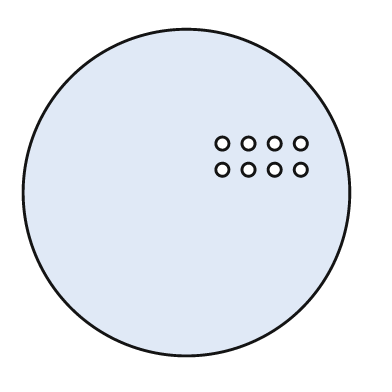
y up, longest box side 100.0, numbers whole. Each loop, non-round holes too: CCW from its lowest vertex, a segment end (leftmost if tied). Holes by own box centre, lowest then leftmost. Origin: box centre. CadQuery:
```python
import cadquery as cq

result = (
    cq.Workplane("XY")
    .moveTo(0.0, 0.0)
    .circle(50.0)
    .moveTo(11.0, 7.0)
    .circle(2.0)
    .moveTo(19.0, 7.0)
    .circle(2.0)
    .moveTo(27.0, 7.0)
    .circle(2.0)
    .moveTo(35.0, 7.0)
    .circle(2.0)
    .moveTo(11.0, 15.0)
    .circle(2.0)
    .moveTo(19.0, 15.0)
    .circle(2.0)
    .moveTo(27.0, 15.0)
    .circle(2.0)
    .moveTo(35.0, 15.0)
    .circle(2.0)
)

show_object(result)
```